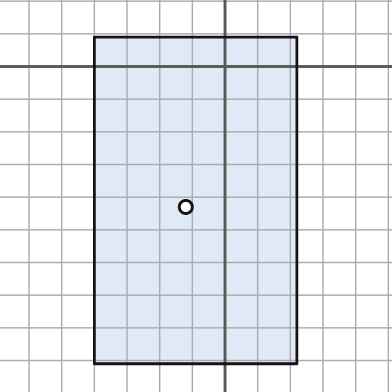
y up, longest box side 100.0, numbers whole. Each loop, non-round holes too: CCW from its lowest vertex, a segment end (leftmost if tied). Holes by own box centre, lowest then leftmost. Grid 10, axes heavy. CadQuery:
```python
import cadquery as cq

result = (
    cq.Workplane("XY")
    .moveTo(-40.0, -91.0)
    .lineTo(22.0, -91.0)
    .lineTo(22.0, 9.0)
    .lineTo(-40.0, 9.0)
    .close()
    .moveTo(-12.0, -43.0)
    .circle(2.0)
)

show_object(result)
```